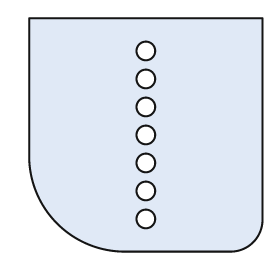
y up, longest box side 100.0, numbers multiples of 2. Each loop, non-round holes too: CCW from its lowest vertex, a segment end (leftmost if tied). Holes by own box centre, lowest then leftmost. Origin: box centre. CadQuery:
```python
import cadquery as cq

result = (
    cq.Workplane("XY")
    .moveTo(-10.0, -50.0)
    .lineTo(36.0, -50.0)
    .threePointArc((46.0, -46.0), (50.0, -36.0))
    .lineTo(50.0, 50.0)
    .lineTo(-50.0, 50.0)
    .lineTo(-50.0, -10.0)
    .threePointArc((-38.0, -38.0), (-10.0, -50.0))
    .close()
    .moveTo(0.0, -36.0)
    .circle(4.0)
    .moveTo(0.0, -24.0)
    .circle(4.0)
    .moveTo(0.0, -12.0)
    .circle(4.0)
    .moveTo(0.0, 0.0)
    .circle(4.0)
    .moveTo(0.0, 12.0)
    .circle(4.0)
    .moveTo(0.0, 24.0)
    .circle(4.0)
    .moveTo(0.0, 36.0)
    .circle(4.0)
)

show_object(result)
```